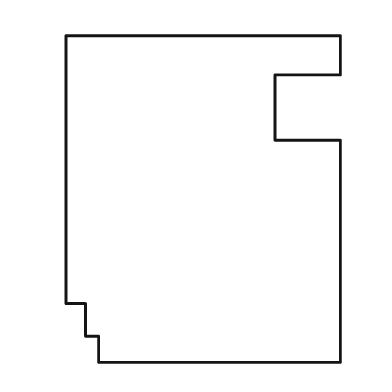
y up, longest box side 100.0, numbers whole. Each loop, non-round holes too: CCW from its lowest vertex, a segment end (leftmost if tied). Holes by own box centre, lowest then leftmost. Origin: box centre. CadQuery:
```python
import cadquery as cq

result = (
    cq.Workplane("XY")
    .moveTo(-32.0, -50.0)
    .lineTo(42.0, -50.0)
    .lineTo(42.0, 18.0)
    .lineTo(22.0, 18.0)
    .lineTo(22.0, 38.0)
    .lineTo(42.0, 38.0)
    .lineTo(42.0, 50.0)
    .lineTo(-42.0, 50.0)
    .lineTo(-42.0, -32.0)
    .lineTo(-36.0, -32.0)
    .lineTo(-36.0, -42.0)
    .lineTo(-32.0, -42.0)
    .close()
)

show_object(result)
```